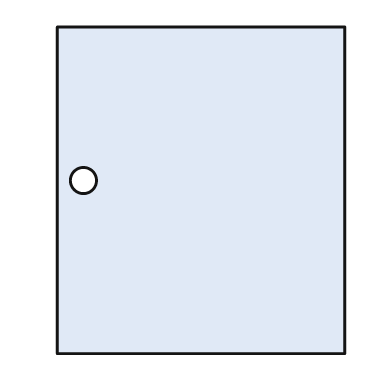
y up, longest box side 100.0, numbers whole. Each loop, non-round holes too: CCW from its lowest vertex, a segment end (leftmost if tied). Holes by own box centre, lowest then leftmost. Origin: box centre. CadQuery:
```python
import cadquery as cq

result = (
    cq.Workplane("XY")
    .moveTo(-44.0, -50.0)
    .lineTo(44.0, -50.0)
    .lineTo(44.0, 50.0)
    .lineTo(-44.0, 50.0)
    .close()
    .moveTo(-36.0, 3.0)
    .circle(4.0)
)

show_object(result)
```